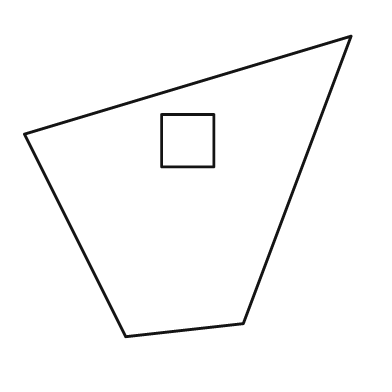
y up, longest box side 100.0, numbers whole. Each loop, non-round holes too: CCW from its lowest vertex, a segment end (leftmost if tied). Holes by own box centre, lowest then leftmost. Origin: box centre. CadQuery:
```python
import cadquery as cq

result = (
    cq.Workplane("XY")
    .moveTo(-19.0, -46.0)
    .lineTo(17.0, -42.0)
    .lineTo(50.0, 46.0)
    .lineTo(-50.0, 16.0)
    .close()
    .moveTo(-8.0, 6.0)
    .lineTo(8.0, 6.0)
    .lineTo(8.0, 22.0)
    .lineTo(-8.0, 22.0)
    .close()
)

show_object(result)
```